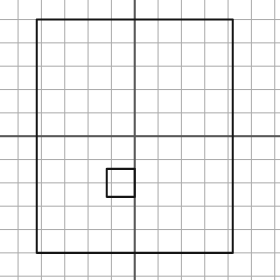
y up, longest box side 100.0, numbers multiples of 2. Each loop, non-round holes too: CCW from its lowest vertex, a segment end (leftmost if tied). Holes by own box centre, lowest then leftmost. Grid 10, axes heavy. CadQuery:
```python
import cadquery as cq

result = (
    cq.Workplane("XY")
    .moveTo(-42.0, -50.0)
    .lineTo(42.0, -50.0)
    .lineTo(42.0, 50.0)
    .lineTo(-42.0, 50.0)
    .close()
    .moveTo(-12.0, -26.0)
    .lineTo(0.0, -26.0)
    .lineTo(0.0, -14.0)
    .lineTo(-12.0, -14.0)
    .close()
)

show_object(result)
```